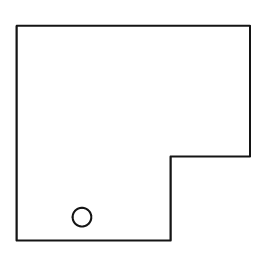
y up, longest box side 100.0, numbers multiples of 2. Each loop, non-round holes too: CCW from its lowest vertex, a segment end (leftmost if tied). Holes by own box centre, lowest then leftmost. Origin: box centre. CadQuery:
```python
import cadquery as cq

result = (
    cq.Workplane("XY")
    .moveTo(-50.0, -46.0)
    .lineTo(16.0, -46.0)
    .lineTo(16.0, -10.0)
    .lineTo(50.0, -10.0)
    .lineTo(50.0, 46.0)
    .lineTo(-50.0, 46.0)
    .close()
    .moveTo(-22.0, -36.0)
    .circle(4.0)
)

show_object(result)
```